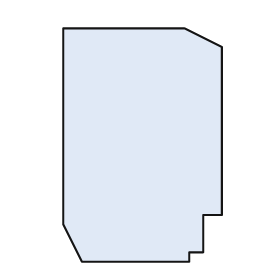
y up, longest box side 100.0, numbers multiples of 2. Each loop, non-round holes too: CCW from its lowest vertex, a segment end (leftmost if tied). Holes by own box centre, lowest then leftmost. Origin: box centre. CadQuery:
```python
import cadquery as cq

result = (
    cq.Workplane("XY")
    .moveTo(-26.0, -50.0)
    .lineTo(20.0, -50.0)
    .lineTo(20.0, -46.0)
    .lineTo(26.0, -46.0)
    .lineTo(26.0, -30.0)
    .lineTo(34.0, -30.0)
    .lineTo(34.0, 42.0)
    .lineTo(18.0, 50.0)
    .lineTo(-34.0, 50.0)
    .lineTo(-34.0, -34.0)
    .close()
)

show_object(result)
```